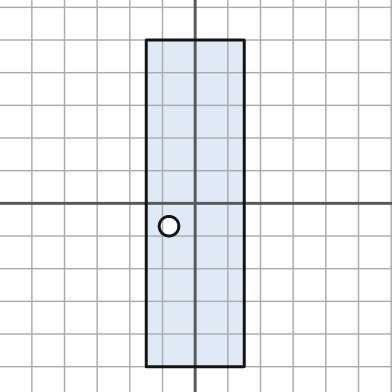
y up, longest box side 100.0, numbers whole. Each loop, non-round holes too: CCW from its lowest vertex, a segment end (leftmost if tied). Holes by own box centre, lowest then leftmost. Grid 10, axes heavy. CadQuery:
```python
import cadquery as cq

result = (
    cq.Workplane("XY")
    .moveTo(-15.0, -50.0)
    .lineTo(15.0, -50.0)
    .lineTo(15.0, 50.0)
    .lineTo(-15.0, 50.0)
    .close()
    .moveTo(-8.0, -7.0)
    .circle(3.0)
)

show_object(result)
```